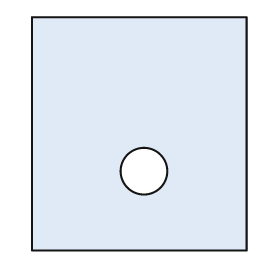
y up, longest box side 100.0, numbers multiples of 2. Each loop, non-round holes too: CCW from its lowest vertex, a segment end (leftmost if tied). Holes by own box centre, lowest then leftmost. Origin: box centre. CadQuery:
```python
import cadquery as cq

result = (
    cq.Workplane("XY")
    .moveTo(-46.0, -50.0)
    .lineTo(46.0, -50.0)
    .lineTo(46.0, 50.0)
    .lineTo(-46.0, 50.0)
    .close()
    .moveTo(2.0, -16.0)
    .circle(10.0)
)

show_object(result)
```